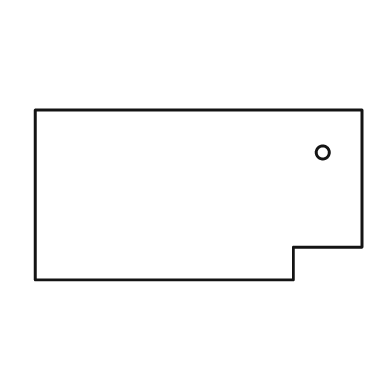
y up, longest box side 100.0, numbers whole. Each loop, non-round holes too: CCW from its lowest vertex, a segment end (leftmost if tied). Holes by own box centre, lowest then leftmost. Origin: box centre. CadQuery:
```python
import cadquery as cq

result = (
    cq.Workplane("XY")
    .moveTo(-50.0, -26.0)
    .lineTo(29.0, -26.0)
    .lineTo(29.0, -16.0)
    .lineTo(50.0, -16.0)
    .lineTo(50.0, 26.0)
    .lineTo(-50.0, 26.0)
    .close()
    .moveTo(38.0, 13.0)
    .circle(2.0)
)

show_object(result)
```